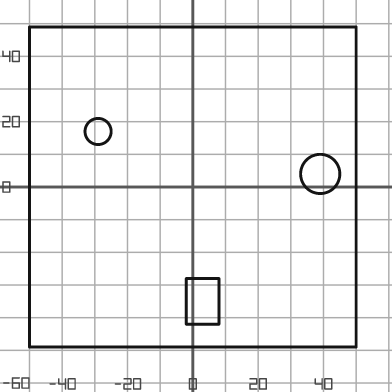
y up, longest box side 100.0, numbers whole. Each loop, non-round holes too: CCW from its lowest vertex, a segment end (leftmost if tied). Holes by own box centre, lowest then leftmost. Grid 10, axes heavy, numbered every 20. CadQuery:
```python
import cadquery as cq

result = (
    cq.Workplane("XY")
    .moveTo(-50.0, -49.0)
    .lineTo(50.0, -49.0)
    .lineTo(50.0, 49.0)
    .lineTo(-50.0, 49.0)
    .close()
    .moveTo(-2.0, -42.0)
    .lineTo(8.0, -42.0)
    .lineTo(8.0, -28.0)
    .lineTo(-2.0, -28.0)
    .close()
    .moveTo(39.0, 4.0)
    .circle(6.0)
    .moveTo(-29.0, 17.0)
    .circle(4.0)
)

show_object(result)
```